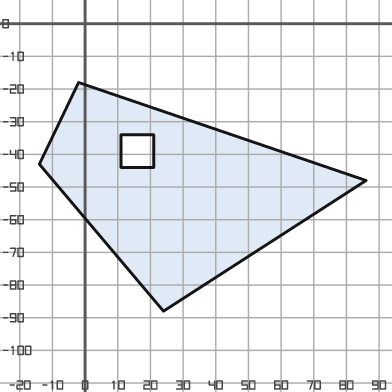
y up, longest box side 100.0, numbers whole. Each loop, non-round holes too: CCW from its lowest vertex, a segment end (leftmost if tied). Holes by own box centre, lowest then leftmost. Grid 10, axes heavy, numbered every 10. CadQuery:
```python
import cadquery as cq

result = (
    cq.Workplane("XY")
    .moveTo(24.0, -88.0)
    .lineTo(86.0, -48.0)
    .lineTo(-2.0, -18.0)
    .lineTo(-14.0, -43.0)
    .close()
    .moveTo(11.0, -44.0)
    .lineTo(21.0, -44.0)
    .lineTo(21.0, -34.0)
    .lineTo(11.0, -34.0)
    .close()
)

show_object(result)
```